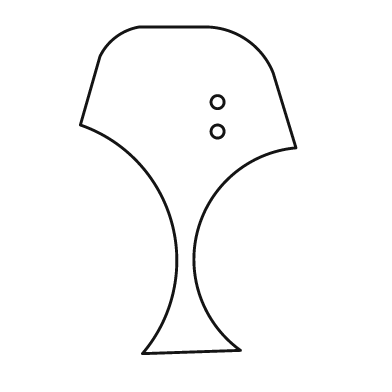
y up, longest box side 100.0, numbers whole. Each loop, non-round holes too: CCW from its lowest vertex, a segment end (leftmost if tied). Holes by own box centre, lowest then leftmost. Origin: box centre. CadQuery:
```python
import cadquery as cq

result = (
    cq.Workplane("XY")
    .moveTo(-14.0, -50.0)
    .lineTo(16.0, -49.0)
    .threePointArc((3.0, -12.0), (33.0, 13.0))
    .lineTo(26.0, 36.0)
    .threePointArc((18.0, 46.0), (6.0, 50.0))
    .lineTo(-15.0, 50.0)
    .threePointArc((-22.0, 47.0), (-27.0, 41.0))
    .lineTo(-33.0, 20.0)
    .threePointArc((-5.0, -10.0), (-14.0, -50.0))
    .close()
    .moveTo(9.0, 18.0)
    .circle(2.0)
    .moveTo(9.0, 27.0)
    .circle(2.0)
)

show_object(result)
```